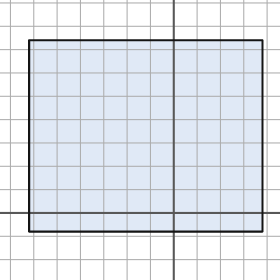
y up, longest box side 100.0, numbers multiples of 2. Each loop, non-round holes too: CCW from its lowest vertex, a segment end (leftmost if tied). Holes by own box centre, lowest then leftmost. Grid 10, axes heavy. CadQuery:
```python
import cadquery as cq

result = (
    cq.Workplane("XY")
    .moveTo(-62.0, -8.0)
    .lineTo(38.0, -8.0)
    .lineTo(38.0, 74.0)
    .lineTo(-62.0, 74.0)
    .close()
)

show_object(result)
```